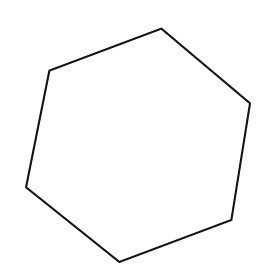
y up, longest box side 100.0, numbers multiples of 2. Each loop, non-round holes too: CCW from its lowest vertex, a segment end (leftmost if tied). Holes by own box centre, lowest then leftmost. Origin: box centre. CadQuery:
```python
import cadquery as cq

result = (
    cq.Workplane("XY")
    .moveTo(-8.0, -50.0)
    .lineTo(40.0, -32.0)
    .lineTo(48.0, 18.0)
    .lineTo(10.0, 50.0)
    .lineTo(-38.0, 32.0)
    .lineTo(-48.0, -18.0)
    .close()
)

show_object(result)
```